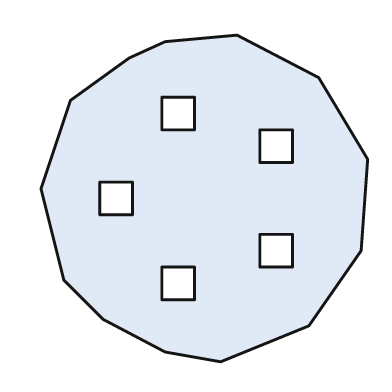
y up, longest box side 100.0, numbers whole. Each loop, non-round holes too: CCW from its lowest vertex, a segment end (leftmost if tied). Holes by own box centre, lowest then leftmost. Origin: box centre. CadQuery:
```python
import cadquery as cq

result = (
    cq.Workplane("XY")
    .moveTo(5.0, -50.0)
    .lineTo(32.0, -39.0)
    .lineTo(48.0, -16.0)
    .lineTo(50.0, 12.0)
    .lineTo(35.0, 37.0)
    .lineTo(10.0, 50.0)
    .lineTo(-12.0, 48.0)
    .lineTo(-23.0, 43.0)
    .lineTo(-41.0, 30.0)
    .lineTo(-50.0, 3.0)
    .lineTo(-43.0, -25.0)
    .lineTo(-31.0, -37.0)
    .lineTo(-12.0, -47.0)
    .close()
    .moveTo(-13.0, -31.0)
    .lineTo(-3.0, -31.0)
    .lineTo(-3.0, -21.0)
    .lineTo(-13.0, -21.0)
    .close()
    .moveTo(17.0, -21.0)
    .lineTo(27.0, -21.0)
    .lineTo(27.0, -11.0)
    .lineTo(17.0, -11.0)
    .close()
    .moveTo(-32.0, -5.0)
    .lineTo(-22.0, -5.0)
    .lineTo(-22.0, 5.0)
    .lineTo(-32.0, 5.0)
    .close()
    .moveTo(17.0, 11.0)
    .lineTo(27.0, 11.0)
    .lineTo(27.0, 21.0)
    .lineTo(17.0, 21.0)
    .close()
    .moveTo(-13.0, 21.0)
    .lineTo(-3.0, 21.0)
    .lineTo(-3.0, 31.0)
    .lineTo(-13.0, 31.0)
    .close()
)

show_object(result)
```